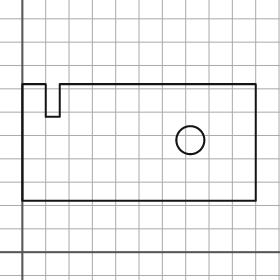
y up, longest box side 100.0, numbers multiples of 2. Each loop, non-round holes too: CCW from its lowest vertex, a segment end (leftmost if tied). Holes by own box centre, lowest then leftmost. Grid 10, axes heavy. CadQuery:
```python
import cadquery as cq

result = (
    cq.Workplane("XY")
    .moveTo(0.0, 22.0)
    .lineTo(100.0, 22.0)
    .lineTo(100.0, 72.0)
    .lineTo(16.0, 72.0)
    .lineTo(16.0, 58.0)
    .lineTo(10.0, 58.0)
    .lineTo(10.0, 72.0)
    .lineTo(0.0, 72.0)
    .close()
    .moveTo(72.0, 48.0)
    .circle(6.0)
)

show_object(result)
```